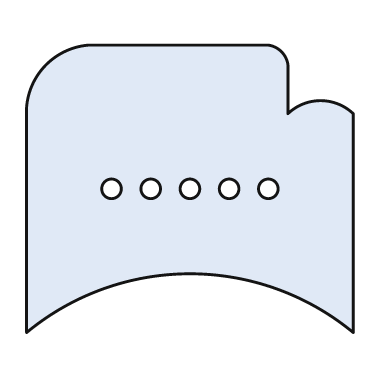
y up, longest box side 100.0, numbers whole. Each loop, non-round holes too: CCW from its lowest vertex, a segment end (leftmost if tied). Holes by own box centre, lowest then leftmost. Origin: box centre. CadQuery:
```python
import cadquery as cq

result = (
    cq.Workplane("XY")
    .moveTo(-50.0, -44.0)
    .threePointArc((0.0, -26.0), (50.0, -44.0))
    .lineTo(50.0, 23.0)
    .threePointArc((40.0, 27.0), (30.0, 23.0))
    .lineTo(30.0, 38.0)
    .threePointArc((28.0, 42.0), (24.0, 44.0))
    .lineTo(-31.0, 44.0)
    .threePointArc((-44.0, 38.0), (-50.0, 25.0))
    .close()
    .moveTo(-24.0, 0.0)
    .circle(3.0)
    .moveTo(-12.0, 0.0)
    .circle(3.0)
    .moveTo(0.0, 0.0)
    .circle(3.0)
    .moveTo(12.0, 0.0)
    .circle(3.0)
    .moveTo(24.0, 0.0)
    .circle(3.0)
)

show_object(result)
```